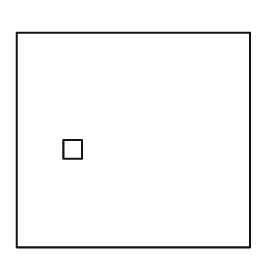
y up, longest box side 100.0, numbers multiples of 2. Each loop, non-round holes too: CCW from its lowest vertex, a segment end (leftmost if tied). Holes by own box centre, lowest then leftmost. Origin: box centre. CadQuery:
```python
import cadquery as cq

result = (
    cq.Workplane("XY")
    .moveTo(-50.0, -46.0)
    .lineTo(50.0, -46.0)
    .lineTo(50.0, 46.0)
    .lineTo(-50.0, 46.0)
    .close()
    .moveTo(-30.0, -8.0)
    .lineTo(-22.0, -8.0)
    .lineTo(-22.0, 0.0)
    .lineTo(-30.0, 0.0)
    .close()
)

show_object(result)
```